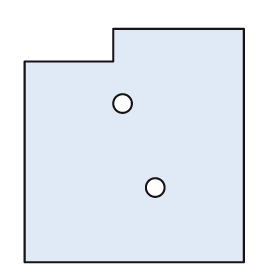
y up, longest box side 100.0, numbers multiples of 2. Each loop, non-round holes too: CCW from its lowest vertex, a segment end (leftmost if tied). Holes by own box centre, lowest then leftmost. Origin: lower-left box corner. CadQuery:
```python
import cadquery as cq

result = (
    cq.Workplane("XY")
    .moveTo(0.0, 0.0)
    .lineTo(94.0, 0.0)
    .lineTo(94.0, 100.0)
    .lineTo(38.0, 100.0)
    .lineTo(38.0, 86.0)
    .lineTo(0.0, 86.0)
    .close()
    .moveTo(56.0, 32.0)
    .circle(4.0)
    .moveTo(42.0, 68.0)
    .circle(4.0)
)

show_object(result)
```